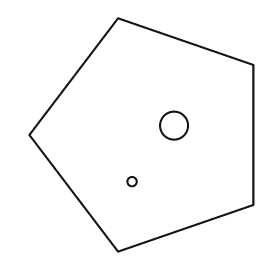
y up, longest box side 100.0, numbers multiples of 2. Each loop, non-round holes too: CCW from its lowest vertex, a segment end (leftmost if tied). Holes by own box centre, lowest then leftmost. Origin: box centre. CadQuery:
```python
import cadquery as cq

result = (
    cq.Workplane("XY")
    .moveTo(-10.0, -50.0)
    .lineTo(48.0, -30.0)
    .lineTo(48.0, 30.0)
    .lineTo(-10.0, 50.0)
    .lineTo(-48.0, 0.0)
    .close()
    .moveTo(-4.0, -20.0)
    .circle(2.0)
    .moveTo(14.0, 4.0)
    .circle(6.0)
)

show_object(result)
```